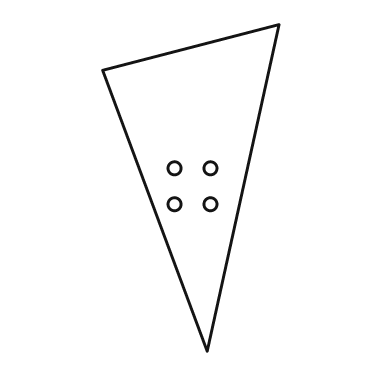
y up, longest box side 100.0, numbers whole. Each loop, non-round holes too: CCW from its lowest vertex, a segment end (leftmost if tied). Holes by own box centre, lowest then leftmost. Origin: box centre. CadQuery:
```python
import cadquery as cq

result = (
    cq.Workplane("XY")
    .moveTo(5.0, -50.0)
    .lineTo(27.0, 50.0)
    .lineTo(-27.0, 36.0)
    .close()
    .moveTo(-5.0, -5.0)
    .circle(2.0)
    .moveTo(6.0, -5.0)
    .circle(2.0)
    .moveTo(-5.0, 6.0)
    .circle(2.0)
    .moveTo(6.0, 6.0)
    .circle(2.0)
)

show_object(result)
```